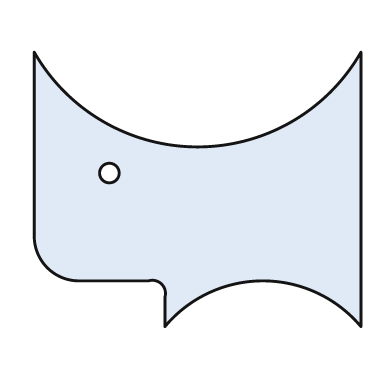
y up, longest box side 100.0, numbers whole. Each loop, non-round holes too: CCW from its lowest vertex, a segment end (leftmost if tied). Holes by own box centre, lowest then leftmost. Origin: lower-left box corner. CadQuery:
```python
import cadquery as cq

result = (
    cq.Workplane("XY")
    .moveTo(40.0, 0.0)
    .threePointArc((70.0, 14.0), (100.0, 0.0))
    .lineTo(100.0, 84.0)
    .threePointArc((50.0, 55.0), (0.0, 84.0))
    .lineTo(0.0, 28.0)
    .threePointArc((4.0, 18.0), (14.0, 14.0))
    .lineTo(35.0, 14.0)
    .threePointArc((39.0, 13.0), (40.0, 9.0))
    .close()
    .moveTo(23.0, 47.0)
    .circle(3.0)
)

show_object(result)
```